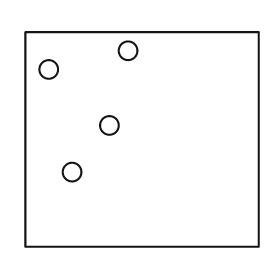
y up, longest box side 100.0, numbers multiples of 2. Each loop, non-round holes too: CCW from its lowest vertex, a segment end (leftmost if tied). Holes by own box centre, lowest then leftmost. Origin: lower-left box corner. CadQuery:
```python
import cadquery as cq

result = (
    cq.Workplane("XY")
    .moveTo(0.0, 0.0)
    .lineTo(100.0, 0.0)
    .lineTo(100.0, 92.0)
    .lineTo(0.0, 92.0)
    .close()
    .moveTo(20.0, 32.0)
    .circle(4.0)
    .moveTo(36.0, 52.0)
    .circle(4.0)
    .moveTo(10.0, 76.0)
    .circle(4.0)
    .moveTo(44.0, 84.0)
    .circle(4.0)
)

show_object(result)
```